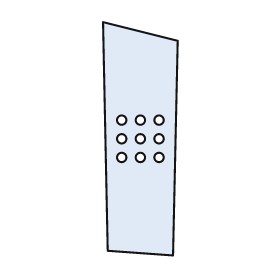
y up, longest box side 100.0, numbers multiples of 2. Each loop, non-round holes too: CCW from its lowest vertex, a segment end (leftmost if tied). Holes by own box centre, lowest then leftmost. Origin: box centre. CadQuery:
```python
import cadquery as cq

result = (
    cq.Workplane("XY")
    .moveTo(14.0, -50.0)
    .lineTo(16.0, 42.0)
    .lineTo(-16.0, 50.0)
    .lineTo(-14.0, -48.0)
    .close()
    .moveTo(-8.0, -8.0)
    .circle(2.0)
    .moveTo(0.0, -8.0)
    .circle(2.0)
    .moveTo(8.0, -8.0)
    .circle(2.0)
    .moveTo(-8.0, 0.0)
    .circle(2.0)
    .moveTo(0.0, 0.0)
    .circle(2.0)
    .moveTo(8.0, 0.0)
    .circle(2.0)
    .moveTo(-8.0, 8.0)
    .circle(2.0)
    .moveTo(0.0, 8.0)
    .circle(2.0)
    .moveTo(8.0, 8.0)
    .circle(2.0)
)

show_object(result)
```